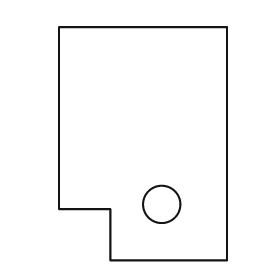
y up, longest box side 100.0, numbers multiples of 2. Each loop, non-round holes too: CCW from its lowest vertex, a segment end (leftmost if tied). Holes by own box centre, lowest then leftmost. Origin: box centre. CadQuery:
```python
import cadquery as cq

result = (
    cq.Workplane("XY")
    .moveTo(-14.0, -50.0)
    .lineTo(36.0, -50.0)
    .lineTo(36.0, 50.0)
    .lineTo(-36.0, 50.0)
    .lineTo(-36.0, -28.0)
    .lineTo(-14.0, -28.0)
    .close()
    .moveTo(8.0, -26.0)
    .circle(8.0)
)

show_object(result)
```